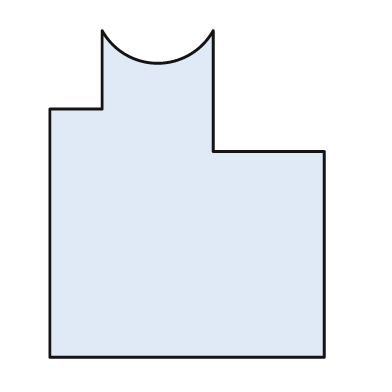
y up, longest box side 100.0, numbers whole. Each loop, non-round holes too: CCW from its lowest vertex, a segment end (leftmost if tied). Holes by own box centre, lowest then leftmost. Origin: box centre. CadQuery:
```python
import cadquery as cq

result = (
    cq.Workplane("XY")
    .moveTo(-42.0, -50.0)
    .lineTo(42.0, -50.0)
    .lineTo(42.0, 13.0)
    .lineTo(8.0, 13.0)
    .lineTo(8.0, 50.0)
    .threePointArc((-9.0, 40.0), (-26.0, 50.0))
    .lineTo(-26.0, 26.0)
    .lineTo(-42.0, 26.0)
    .close()
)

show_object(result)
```